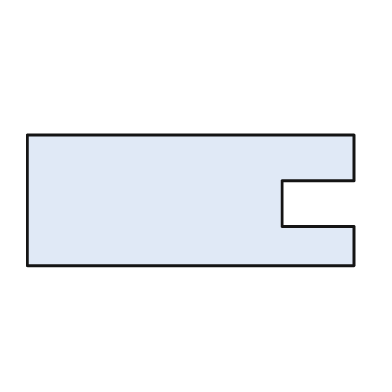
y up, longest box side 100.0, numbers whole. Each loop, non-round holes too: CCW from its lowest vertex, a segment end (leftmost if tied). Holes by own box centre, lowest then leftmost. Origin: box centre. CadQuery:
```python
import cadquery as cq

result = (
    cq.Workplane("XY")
    .moveTo(-50.0, -20.0)
    .lineTo(50.0, -20.0)
    .lineTo(50.0, -8.0)
    .lineTo(28.0, -8.0)
    .lineTo(28.0, 6.0)
    .lineTo(50.0, 6.0)
    .lineTo(50.0, 20.0)
    .lineTo(-50.0, 20.0)
    .close()
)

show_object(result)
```